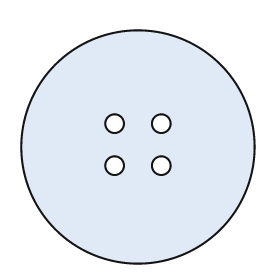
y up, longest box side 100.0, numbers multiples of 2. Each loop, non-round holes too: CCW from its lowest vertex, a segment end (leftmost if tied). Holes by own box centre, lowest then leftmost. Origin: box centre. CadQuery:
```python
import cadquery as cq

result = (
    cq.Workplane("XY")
    .moveTo(0.0, 0.0)
    .circle(50.0)
    .moveTo(-10.0, -8.0)
    .circle(4.0)
    .moveTo(10.0, -8.0)
    .circle(4.0)
    .moveTo(-10.0, 10.0)
    .circle(4.0)
    .moveTo(10.0, 10.0)
    .circle(4.0)
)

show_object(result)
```